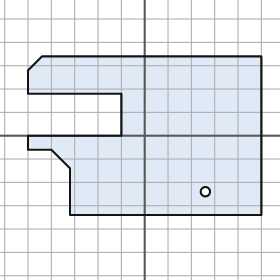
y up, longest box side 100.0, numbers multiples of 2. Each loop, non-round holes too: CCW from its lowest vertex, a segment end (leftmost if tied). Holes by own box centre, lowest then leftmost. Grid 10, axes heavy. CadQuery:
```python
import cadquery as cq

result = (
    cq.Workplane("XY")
    .moveTo(-32.0, -34.0)
    .lineTo(50.0, -34.0)
    .lineTo(50.0, 34.0)
    .lineTo(-44.0, 34.0)
    .lineTo(-50.0, 28.0)
    .lineTo(-50.0, 18.0)
    .lineTo(-10.0, 18.0)
    .lineTo(-10.0, 0.0)
    .lineTo(-50.0, 0.0)
    .lineTo(-50.0, -6.0)
    .lineTo(-40.0, -6.0)
    .lineTo(-32.0, -14.0)
    .close()
    .moveTo(26.0, -24.0)
    .circle(2.0)
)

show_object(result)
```